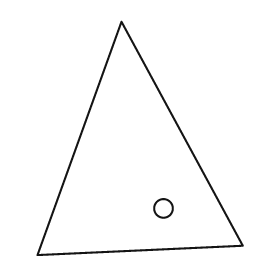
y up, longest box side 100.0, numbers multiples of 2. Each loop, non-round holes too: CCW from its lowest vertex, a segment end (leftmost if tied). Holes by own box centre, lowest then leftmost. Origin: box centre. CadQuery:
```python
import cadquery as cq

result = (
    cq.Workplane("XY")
    .moveTo(-44.0, -50.0)
    .lineTo(44.0, -46.0)
    .lineTo(-8.0, 50.0)
    .close()
    .moveTo(10.0, -30.0)
    .circle(4.0)
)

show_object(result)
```